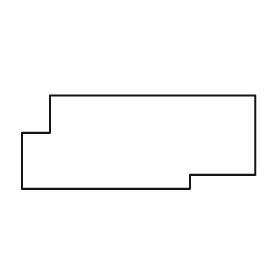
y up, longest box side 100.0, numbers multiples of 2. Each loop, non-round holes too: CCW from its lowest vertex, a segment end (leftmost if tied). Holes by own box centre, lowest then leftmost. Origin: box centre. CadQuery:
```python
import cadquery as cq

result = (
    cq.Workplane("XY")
    .moveTo(-50.0, -20.0)
    .lineTo(22.0, -20.0)
    .lineTo(22.0, -14.0)
    .lineTo(50.0, -14.0)
    .lineTo(50.0, 20.0)
    .lineTo(-38.0, 20.0)
    .lineTo(-38.0, 4.0)
    .lineTo(-50.0, 4.0)
    .close()
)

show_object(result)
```